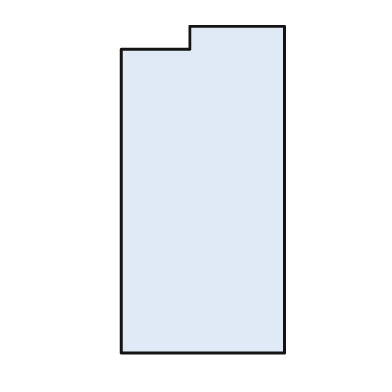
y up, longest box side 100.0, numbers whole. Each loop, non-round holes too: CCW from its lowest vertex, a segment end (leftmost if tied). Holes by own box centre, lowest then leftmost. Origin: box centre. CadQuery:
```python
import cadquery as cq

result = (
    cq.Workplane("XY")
    .moveTo(-25.0, -50.0)
    .lineTo(25.0, -50.0)
    .lineTo(25.0, 50.0)
    .lineTo(-4.0, 50.0)
    .lineTo(-4.0, 43.0)
    .lineTo(-25.0, 43.0)
    .close()
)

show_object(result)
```